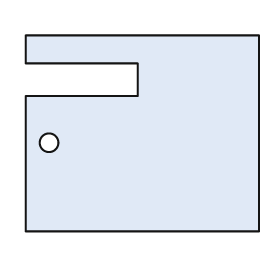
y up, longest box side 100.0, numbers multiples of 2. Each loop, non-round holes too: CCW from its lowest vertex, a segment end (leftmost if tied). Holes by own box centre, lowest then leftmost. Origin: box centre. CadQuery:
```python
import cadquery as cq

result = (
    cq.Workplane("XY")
    .moveTo(-50.0, -42.0)
    .lineTo(50.0, -42.0)
    .lineTo(50.0, 42.0)
    .lineTo(-50.0, 42.0)
    .lineTo(-50.0, 30.0)
    .lineTo(-2.0, 30.0)
    .lineTo(-2.0, 16.0)
    .lineTo(-50.0, 16.0)
    .close()
    .moveTo(-40.0, -4.0)
    .circle(4.0)
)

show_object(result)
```